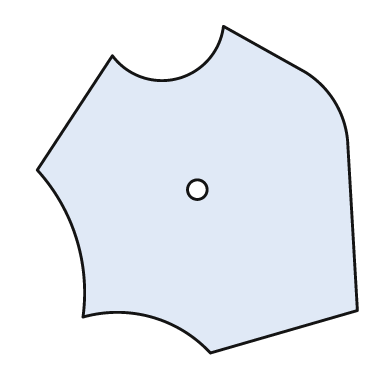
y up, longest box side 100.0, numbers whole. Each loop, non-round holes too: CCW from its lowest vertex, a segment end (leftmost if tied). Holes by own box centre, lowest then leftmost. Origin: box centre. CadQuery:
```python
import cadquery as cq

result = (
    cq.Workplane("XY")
    .moveTo(4.0, -50.0)
    .lineTo(49.0, -37.0)
    .lineTo(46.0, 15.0)
    .threePointArc((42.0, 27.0), (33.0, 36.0))
    .lineTo(8.0, 50.0)
    .threePointArc((-6.0, 34.0), (-26.0, 41.0))
    .lineTo(-49.0, 6.0)
    .threePointArc((-37.0, -15.0), (-35.0, -39.0))
    .threePointArc((-14.0, -39.0), (4.0, -50.0))
    .close()
    .moveTo(0.0, 0.0)
    .circle(3.0)
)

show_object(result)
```